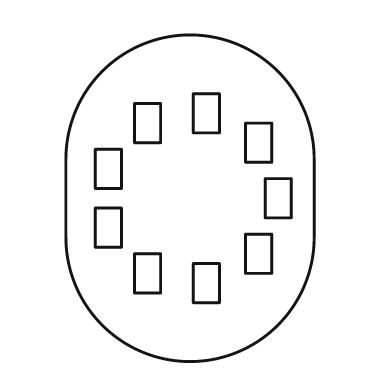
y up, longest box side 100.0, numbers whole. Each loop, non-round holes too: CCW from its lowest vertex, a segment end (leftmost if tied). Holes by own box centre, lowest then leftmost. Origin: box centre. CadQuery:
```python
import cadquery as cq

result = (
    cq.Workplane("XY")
    .moveTo(-38.0, -12.0)
    .threePointArc((0.0, -50.0), (38.0, -12.0))
    .lineTo(38.0, 12.0)
    .threePointArc((0.0, 50.0), (-38.0, 12.0))
    .close()
    .moveTo(1.0, -32.0)
    .lineTo(9.0, -32.0)
    .lineTo(9.0, -20.0)
    .lineTo(1.0, -20.0)
    .close()
    .moveTo(-17.0, -29.0)
    .lineTo(-9.0, -29.0)
    .lineTo(-9.0, -17.0)
    .lineTo(-17.0, -17.0)
    .close()
    .moveTo(17.0, -23.0)
    .lineTo(25.0, -23.0)
    .lineTo(25.0, -11.0)
    .lineTo(17.0, -11.0)
    .close()
    .moveTo(-29.0, -15.0)
    .lineTo(-21.0, -15.0)
    .lineTo(-21.0, -3.0)
    .lineTo(-29.0, -3.0)
    .close()
    .moveTo(23.0, -6.0)
    .lineTo(31.0, -6.0)
    .lineTo(31.0, 6.0)
    .lineTo(23.0, 6.0)
    .close()
    .moveTo(-29.0, 3.0)
    .lineTo(-21.0, 3.0)
    .lineTo(-21.0, 15.0)
    .lineTo(-29.0, 15.0)
    .close()
    .moveTo(17.0, 11.0)
    .lineTo(25.0, 11.0)
    .lineTo(25.0, 23.0)
    .lineTo(17.0, 23.0)
    .close()
    .moveTo(-17.0, 17.0)
    .lineTo(-9.0, 17.0)
    .lineTo(-9.0, 29.0)
    .lineTo(-17.0, 29.0)
    .close()
    .moveTo(1.0, 20.0)
    .lineTo(9.0, 20.0)
    .lineTo(9.0, 32.0)
    .lineTo(1.0, 32.0)
    .close()
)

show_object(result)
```